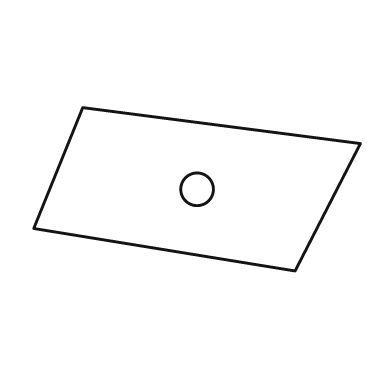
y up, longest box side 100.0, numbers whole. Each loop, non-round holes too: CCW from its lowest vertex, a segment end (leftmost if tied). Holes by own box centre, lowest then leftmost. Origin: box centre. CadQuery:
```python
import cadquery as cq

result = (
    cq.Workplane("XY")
    .moveTo(30.0, -25.0)
    .lineTo(50.0, 14.0)
    .lineTo(-35.0, 25.0)
    .lineTo(-50.0, -12.0)
    .close()
    .moveTo(0.0, 0.0)
    .circle(5.0)
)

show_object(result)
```